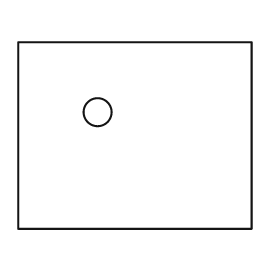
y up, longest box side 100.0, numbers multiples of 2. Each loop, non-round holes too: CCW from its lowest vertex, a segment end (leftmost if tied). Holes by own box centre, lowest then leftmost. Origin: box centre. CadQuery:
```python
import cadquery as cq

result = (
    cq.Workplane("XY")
    .moveTo(-50.0, -40.0)
    .lineTo(50.0, -40.0)
    .lineTo(50.0, 40.0)
    .lineTo(-50.0, 40.0)
    .close()
    .moveTo(-16.0, 10.0)
    .circle(6.0)
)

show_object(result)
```